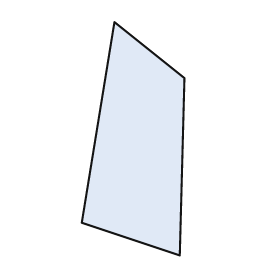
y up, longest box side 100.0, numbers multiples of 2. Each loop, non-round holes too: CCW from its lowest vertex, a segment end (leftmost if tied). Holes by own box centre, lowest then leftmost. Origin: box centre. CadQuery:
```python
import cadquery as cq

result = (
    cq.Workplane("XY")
    .moveTo(20.0, -50.0)
    .lineTo(22.0, 26.0)
    .lineTo(-8.0, 50.0)
    .lineTo(-22.0, -36.0)
    .close()
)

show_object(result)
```